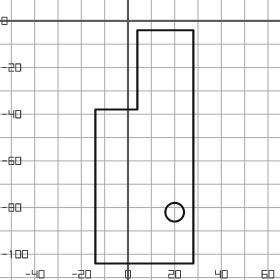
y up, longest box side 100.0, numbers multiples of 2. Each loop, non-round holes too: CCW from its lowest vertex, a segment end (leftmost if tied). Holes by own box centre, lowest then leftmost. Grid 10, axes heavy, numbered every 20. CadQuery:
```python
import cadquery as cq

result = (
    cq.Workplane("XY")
    .moveTo(-14.0, -104.0)
    .lineTo(28.0, -104.0)
    .lineTo(28.0, -4.0)
    .lineTo(4.0, -4.0)
    .lineTo(4.0, -38.0)
    .lineTo(-14.0, -38.0)
    .close()
    .moveTo(20.0, -82.0)
    .circle(4.0)
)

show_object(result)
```